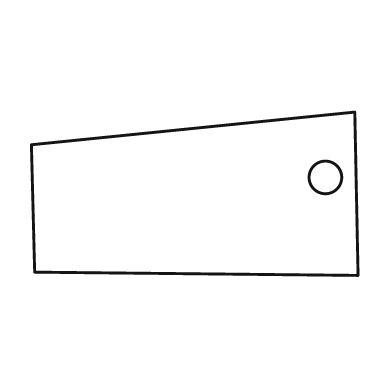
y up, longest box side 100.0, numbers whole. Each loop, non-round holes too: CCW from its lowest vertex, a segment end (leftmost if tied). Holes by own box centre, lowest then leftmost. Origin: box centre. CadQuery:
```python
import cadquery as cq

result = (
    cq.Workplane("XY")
    .moveTo(50.0, -25.0)
    .lineTo(49.0, 25.0)
    .lineTo(-50.0, 15.0)
    .lineTo(-49.0, -24.0)
    .close()
    .moveTo(40.0, 5.0)
    .circle(5.0)
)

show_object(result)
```